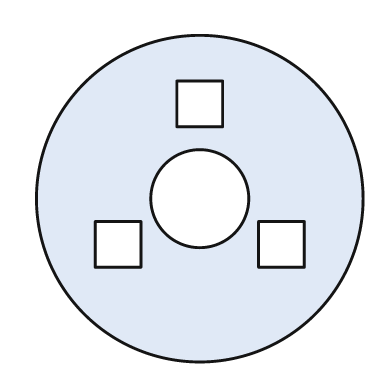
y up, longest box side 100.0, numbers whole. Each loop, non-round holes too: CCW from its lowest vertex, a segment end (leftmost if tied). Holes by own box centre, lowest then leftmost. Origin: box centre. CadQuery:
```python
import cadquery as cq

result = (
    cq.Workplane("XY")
    .moveTo(0.0, 0.0)
    .circle(50.0)
    .moveTo(-32.0, -21.0)
    .lineTo(-18.0, -21.0)
    .lineTo(-18.0, -7.0)
    .lineTo(-32.0, -7.0)
    .close()
    .moveTo(18.0, -21.0)
    .lineTo(32.0, -21.0)
    .lineTo(32.0, -7.0)
    .lineTo(18.0, -7.0)
    .close()
    .moveTo(0.0, 0.0)
    .circle(15.0)
    .moveTo(-7.0, 22.0)
    .lineTo(7.0, 22.0)
    .lineTo(7.0, 36.0)
    .lineTo(-7.0, 36.0)
    .close()
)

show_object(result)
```